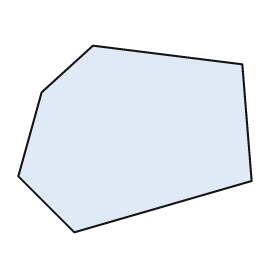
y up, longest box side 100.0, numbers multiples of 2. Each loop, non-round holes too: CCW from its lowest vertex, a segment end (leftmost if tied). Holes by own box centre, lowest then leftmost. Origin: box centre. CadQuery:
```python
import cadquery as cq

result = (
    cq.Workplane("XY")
    .moveTo(-26.0, -40.0)
    .lineTo(50.0, -18.0)
    .lineTo(46.0, 32.0)
    .lineTo(-18.0, 40.0)
    .lineTo(-40.0, 20.0)
    .lineTo(-50.0, -16.0)
    .close()
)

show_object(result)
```